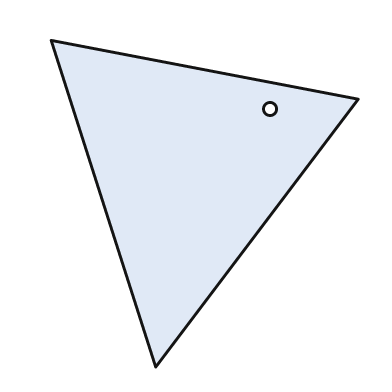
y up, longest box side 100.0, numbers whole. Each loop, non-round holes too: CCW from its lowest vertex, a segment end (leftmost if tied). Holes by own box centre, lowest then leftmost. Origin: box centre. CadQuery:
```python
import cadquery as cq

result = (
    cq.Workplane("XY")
    .moveTo(-15.0, -50.0)
    .lineTo(47.0, 32.0)
    .lineTo(-47.0, 50.0)
    .close()
    .moveTo(20.0, 29.0)
    .circle(2.0)
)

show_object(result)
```